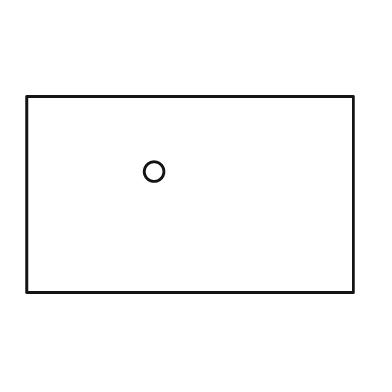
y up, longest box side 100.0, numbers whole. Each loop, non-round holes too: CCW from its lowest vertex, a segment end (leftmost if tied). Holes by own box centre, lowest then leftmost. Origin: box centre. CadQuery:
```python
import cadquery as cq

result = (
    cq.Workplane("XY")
    .moveTo(-50.0, -30.0)
    .lineTo(50.0, -30.0)
    .lineTo(50.0, 30.0)
    .lineTo(-50.0, 30.0)
    .close()
    .moveTo(-11.0, 7.0)
    .circle(3.0)
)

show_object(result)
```